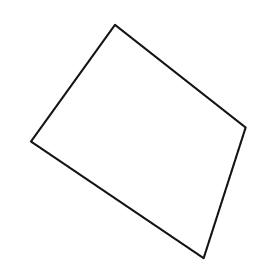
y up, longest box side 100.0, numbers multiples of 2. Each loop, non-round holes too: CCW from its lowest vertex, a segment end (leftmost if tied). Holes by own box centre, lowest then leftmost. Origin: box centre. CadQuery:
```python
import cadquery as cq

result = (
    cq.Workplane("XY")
    .moveTo(28.0, -50.0)
    .lineTo(46.0, 6.0)
    .lineTo(-10.0, 50.0)
    .lineTo(-46.0, 0.0)
    .close()
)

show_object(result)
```